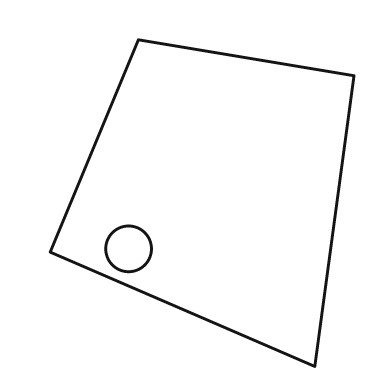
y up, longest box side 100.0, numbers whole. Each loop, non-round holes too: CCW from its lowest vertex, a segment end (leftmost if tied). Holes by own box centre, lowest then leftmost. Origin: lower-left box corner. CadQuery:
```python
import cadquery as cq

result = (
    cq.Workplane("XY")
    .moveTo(81.0, 0.0)
    .lineTo(93.0, 89.0)
    .lineTo(27.0, 100.0)
    .lineTo(0.0, 35.0)
    .close()
    .moveTo(24.0, 36.0)
    .circle(7.0)
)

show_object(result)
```